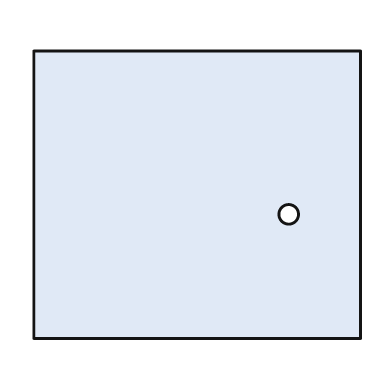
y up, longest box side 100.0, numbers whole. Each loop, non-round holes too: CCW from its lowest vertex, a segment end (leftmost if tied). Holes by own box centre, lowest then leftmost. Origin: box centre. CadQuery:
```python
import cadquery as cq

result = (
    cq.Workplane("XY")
    .moveTo(-50.0, -44.0)
    .lineTo(50.0, -44.0)
    .lineTo(50.0, 44.0)
    .lineTo(-50.0, 44.0)
    .close()
    .moveTo(28.0, -6.0)
    .circle(3.0)
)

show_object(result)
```